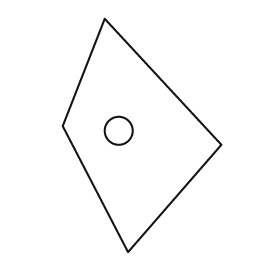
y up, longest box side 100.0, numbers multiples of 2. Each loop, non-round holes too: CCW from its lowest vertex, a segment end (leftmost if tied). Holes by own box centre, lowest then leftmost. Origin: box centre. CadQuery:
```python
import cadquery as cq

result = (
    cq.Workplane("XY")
    .moveTo(-6.0, -50.0)
    .lineTo(34.0, -4.0)
    .lineTo(-16.0, 50.0)
    .lineTo(-34.0, 4.0)
    .close()
    .moveTo(-10.0, 2.0)
    .circle(6.0)
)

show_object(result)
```